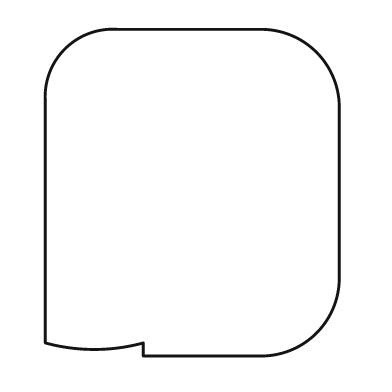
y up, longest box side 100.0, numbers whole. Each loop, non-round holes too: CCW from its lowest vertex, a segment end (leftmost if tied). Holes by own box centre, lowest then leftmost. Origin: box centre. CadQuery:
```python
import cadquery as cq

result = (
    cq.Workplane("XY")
    .moveTo(-15.0, -50.0)
    .lineTo(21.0, -50.0)
    .threePointArc((38.0, -43.0), (45.0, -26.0))
    .lineTo(45.0, 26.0)
    .threePointArc((38.0, 43.0), (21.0, 50.0))
    .lineTo(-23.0, 50.0)
    .threePointArc((-39.0, 44.0), (-45.0, 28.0))
    .lineTo(-45.0, -46.0)
    .threePointArc((-30.0, -48.0), (-15.0, -46.0))
    .close()
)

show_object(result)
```